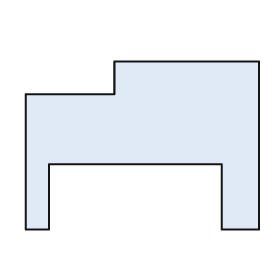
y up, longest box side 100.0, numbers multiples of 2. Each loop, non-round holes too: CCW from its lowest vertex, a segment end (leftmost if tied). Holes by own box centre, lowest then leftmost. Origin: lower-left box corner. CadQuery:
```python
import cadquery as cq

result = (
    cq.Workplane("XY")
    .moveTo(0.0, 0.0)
    .lineTo(10.0, 0.0)
    .lineTo(10.0, 28.0)
    .lineTo(84.0, 28.0)
    .lineTo(84.0, 0.0)
    .lineTo(100.0, 0.0)
    .lineTo(100.0, 72.0)
    .lineTo(38.0, 72.0)
    .lineTo(38.0, 58.0)
    .lineTo(0.0, 58.0)
    .close()
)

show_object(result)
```